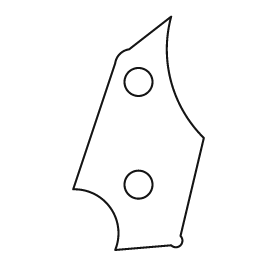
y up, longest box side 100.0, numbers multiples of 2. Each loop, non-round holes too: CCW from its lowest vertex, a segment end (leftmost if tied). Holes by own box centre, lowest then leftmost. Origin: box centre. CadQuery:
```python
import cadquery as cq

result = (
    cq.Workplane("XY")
    .moveTo(-10.0, -50.0)
    .lineTo(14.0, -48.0)
    .threePointArc((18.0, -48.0), (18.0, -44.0))
    .lineTo(28.0, -2.0)
    .threePointArc((14.0, 22.0), (14.0, 50.0))
    .lineTo(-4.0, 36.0)
    .threePointArc((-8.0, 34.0), (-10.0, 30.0))
    .lineTo(-28.0, -24.0)
    .threePointArc((-12.0, -32.0), (-10.0, -50.0))
    .close()
    .moveTo(0.0, -22.0)
    .circle(6.0)
    .moveTo(0.0, 22.0)
    .circle(6.0)
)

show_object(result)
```